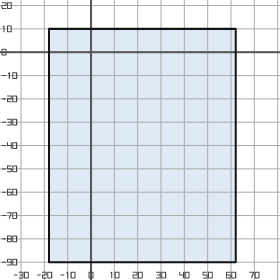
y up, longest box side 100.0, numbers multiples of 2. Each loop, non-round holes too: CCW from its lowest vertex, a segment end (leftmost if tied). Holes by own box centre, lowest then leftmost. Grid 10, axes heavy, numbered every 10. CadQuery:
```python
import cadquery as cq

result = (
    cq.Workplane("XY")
    .moveTo(-18.0, -90.0)
    .lineTo(62.0, -90.0)
    .lineTo(62.0, 10.0)
    .lineTo(-18.0, 10.0)
    .close()
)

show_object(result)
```